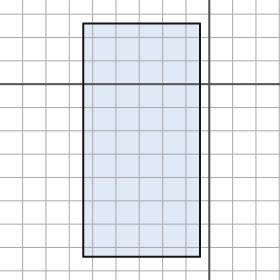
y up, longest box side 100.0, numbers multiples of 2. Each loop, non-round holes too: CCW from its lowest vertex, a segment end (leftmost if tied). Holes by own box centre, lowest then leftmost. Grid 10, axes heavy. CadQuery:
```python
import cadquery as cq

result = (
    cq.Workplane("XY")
    .moveTo(-54.0, -74.0)
    .lineTo(-4.0, -74.0)
    .lineTo(-4.0, 26.0)
    .lineTo(-54.0, 26.0)
    .close()
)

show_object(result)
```